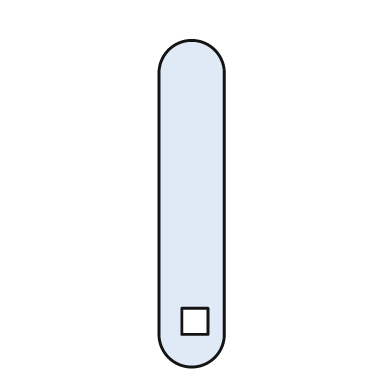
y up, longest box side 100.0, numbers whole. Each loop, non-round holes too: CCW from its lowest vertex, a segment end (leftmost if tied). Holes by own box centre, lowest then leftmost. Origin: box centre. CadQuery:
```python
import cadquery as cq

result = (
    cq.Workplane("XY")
    .moveTo(-10.0, -40.0)
    .threePointArc((0.0, -50.0), (10.0, -40.0))
    .lineTo(10.0, 40.0)
    .threePointArc((0.0, 50.0), (-10.0, 40.0))
    .close()
    .moveTo(-3.0, -40.0)
    .lineTo(5.0, -40.0)
    .lineTo(5.0, -32.0)
    .lineTo(-3.0, -32.0)
    .close()
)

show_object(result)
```